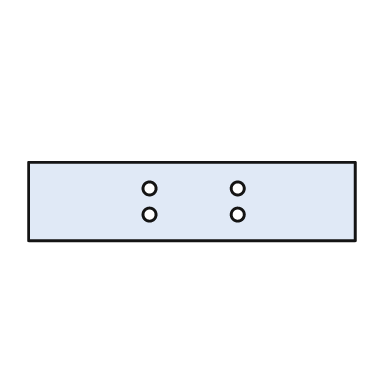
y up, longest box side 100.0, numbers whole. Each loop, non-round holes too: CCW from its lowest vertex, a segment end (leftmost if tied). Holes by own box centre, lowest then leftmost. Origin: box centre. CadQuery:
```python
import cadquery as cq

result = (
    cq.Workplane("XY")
    .moveTo(-50.0, -12.0)
    .lineTo(50.0, -12.0)
    .lineTo(50.0, 12.0)
    .lineTo(-50.0, 12.0)
    .close()
    .moveTo(-13.0, -4.0)
    .circle(2.0)
    .moveTo(14.0, -4.0)
    .circle(2.0)
    .moveTo(-13.0, 4.0)
    .circle(2.0)
    .moveTo(14.0, 4.0)
    .circle(2.0)
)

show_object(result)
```